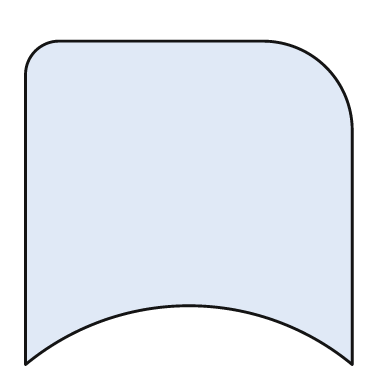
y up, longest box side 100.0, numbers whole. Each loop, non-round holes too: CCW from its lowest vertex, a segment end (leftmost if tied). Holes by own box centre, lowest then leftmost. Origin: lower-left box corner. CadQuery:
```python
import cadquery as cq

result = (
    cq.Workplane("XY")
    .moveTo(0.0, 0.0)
    .threePointArc((50.0, 18.0), (100.0, 0.0))
    .lineTo(100.0, 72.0)
    .threePointArc((92.0, 91.0), (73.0, 99.0))
    .lineTo(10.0, 99.0)
    .threePointArc((3.0, 96.0), (0.0, 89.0))
    .close()
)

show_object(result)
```